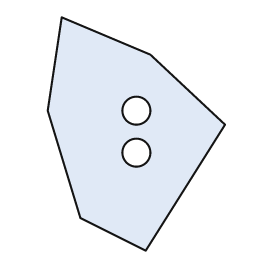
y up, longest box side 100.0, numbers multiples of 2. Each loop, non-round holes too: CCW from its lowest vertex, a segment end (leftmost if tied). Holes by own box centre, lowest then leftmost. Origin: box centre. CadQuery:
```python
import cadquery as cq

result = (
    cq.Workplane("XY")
    .moveTo(4.0, -50.0)
    .lineTo(38.0, 4.0)
    .lineTo(6.0, 34.0)
    .lineTo(-32.0, 50.0)
    .lineTo(-38.0, 10.0)
    .lineTo(-24.0, -36.0)
    .close()
    .moveTo(0.0, -8.0)
    .circle(6.0)
    .moveTo(0.0, 10.0)
    .circle(6.0)
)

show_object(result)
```